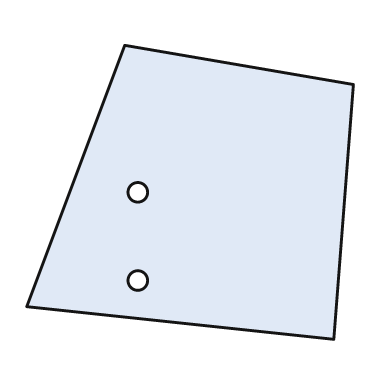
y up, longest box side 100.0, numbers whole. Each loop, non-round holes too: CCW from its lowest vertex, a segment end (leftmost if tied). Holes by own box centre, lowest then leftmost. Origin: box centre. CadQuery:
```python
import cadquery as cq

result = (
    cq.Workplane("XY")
    .moveTo(44.0, -45.0)
    .lineTo(50.0, 33.0)
    .lineTo(-20.0, 45.0)
    .lineTo(-50.0, -35.0)
    .close()
    .moveTo(-16.0, -27.0)
    .circle(3.0)
    .moveTo(-16.0, 0.0)
    .circle(3.0)
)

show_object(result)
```